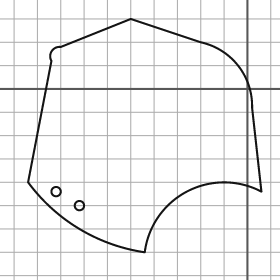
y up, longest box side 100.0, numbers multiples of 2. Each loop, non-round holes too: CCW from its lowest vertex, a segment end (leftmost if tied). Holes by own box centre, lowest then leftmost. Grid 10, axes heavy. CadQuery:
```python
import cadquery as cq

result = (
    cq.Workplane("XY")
    .moveTo(-44.0, -70.0)
    .threePointArc((-26.0, -44.0), (6.0, -44.0))
    .lineTo(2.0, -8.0)
    .threePointArc((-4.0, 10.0), (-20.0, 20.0))
    .lineTo(-50.0, 30.0)
    .lineTo(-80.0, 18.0)
    .threePointArc((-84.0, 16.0), (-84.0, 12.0))
    .lineTo(-94.0, -40.0)
    .threePointArc((-72.0, -60.0), (-44.0, -70.0))
    .close()
    .moveTo(-72.0, -50.0)
    .circle(2.0)
    .moveTo(-82.0, -44.0)
    .circle(2.0)
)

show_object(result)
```